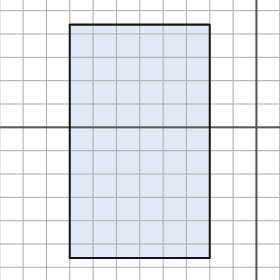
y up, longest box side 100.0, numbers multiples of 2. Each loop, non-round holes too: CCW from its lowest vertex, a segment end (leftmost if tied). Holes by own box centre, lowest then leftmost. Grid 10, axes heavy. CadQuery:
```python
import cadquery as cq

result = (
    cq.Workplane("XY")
    .moveTo(-80.0, -56.0)
    .lineTo(-20.0, -56.0)
    .lineTo(-20.0, 44.0)
    .lineTo(-80.0, 44.0)
    .close()
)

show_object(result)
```